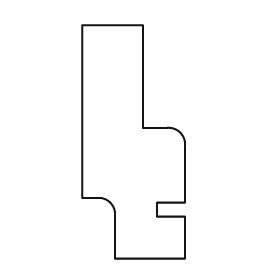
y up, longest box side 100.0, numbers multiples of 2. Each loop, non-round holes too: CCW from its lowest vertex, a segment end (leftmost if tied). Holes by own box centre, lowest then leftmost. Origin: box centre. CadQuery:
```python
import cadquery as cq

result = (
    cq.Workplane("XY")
    .moveTo(-8.0, -50.0)
    .lineTo(22.0, -50.0)
    .lineTo(22.0, -32.0)
    .lineTo(10.0, -32.0)
    .lineTo(10.0, -26.0)
    .lineTo(22.0, -26.0)
    .lineTo(22.0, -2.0)
    .threePointArc((20.0, 4.0), (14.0, 6.0))
    .lineTo(4.0, 6.0)
    .lineTo(4.0, 50.0)
    .lineTo(-22.0, 50.0)
    .lineTo(-22.0, -24.0)
    .lineTo(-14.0, -24.0)
    .threePointArc((-10.0, -26.0), (-8.0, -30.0))
    .close()
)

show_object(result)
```